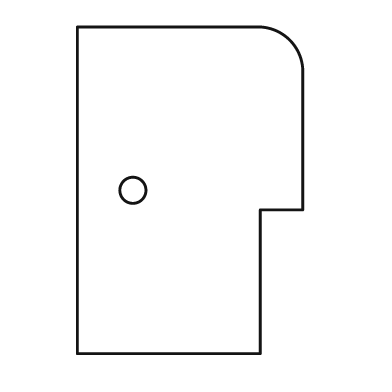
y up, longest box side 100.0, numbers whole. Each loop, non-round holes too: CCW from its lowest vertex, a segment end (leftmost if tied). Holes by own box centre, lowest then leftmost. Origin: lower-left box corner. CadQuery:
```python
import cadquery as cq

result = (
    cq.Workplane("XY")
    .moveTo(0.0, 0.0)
    .lineTo(56.0, 0.0)
    .lineTo(56.0, 44.0)
    .lineTo(69.0, 44.0)
    .lineTo(69.0, 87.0)
    .threePointArc((65.0, 96.0), (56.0, 100.0))
    .lineTo(0.0, 100.0)
    .close()
    .moveTo(17.0, 50.0)
    .circle(4.0)
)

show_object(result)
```